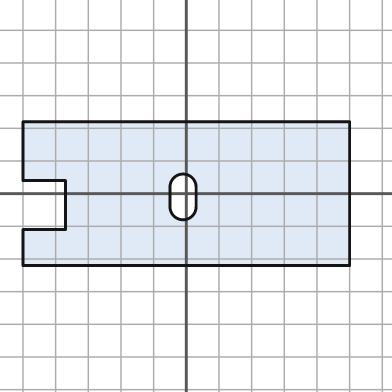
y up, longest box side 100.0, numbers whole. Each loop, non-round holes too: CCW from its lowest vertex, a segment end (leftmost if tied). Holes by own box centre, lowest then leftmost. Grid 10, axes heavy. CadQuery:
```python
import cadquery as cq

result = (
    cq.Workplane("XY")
    .moveTo(-50.0, -22.0)
    .lineTo(50.0, -22.0)
    .lineTo(50.0, 22.0)
    .lineTo(-50.0, 22.0)
    .lineTo(-50.0, 4.0)
    .lineTo(-37.0, 4.0)
    .lineTo(-37.0, -11.0)
    .lineTo(-50.0, -11.0)
    .close()
    .moveTo(-5.0, -4.0)
    .threePointArc((-1.0, -8.0), (3.0, -4.0))
    .lineTo(3.0, 2.0)
    .threePointArc((-1.0, 6.0), (-5.0, 2.0))
    .close()
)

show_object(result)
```